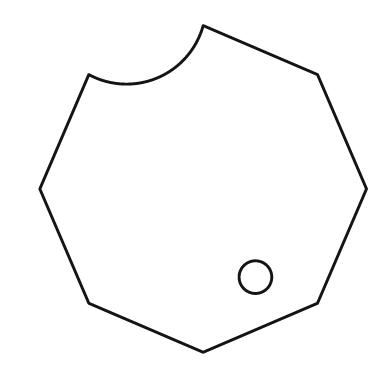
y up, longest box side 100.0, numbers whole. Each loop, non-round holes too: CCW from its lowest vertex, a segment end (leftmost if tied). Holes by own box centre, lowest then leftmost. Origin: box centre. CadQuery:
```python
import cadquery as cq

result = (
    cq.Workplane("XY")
    .moveTo(0.0, -50.0)
    .lineTo(35.0, -35.0)
    .lineTo(50.0, 0.0)
    .lineTo(35.0, 35.0)
    .lineTo(0.0, 50.0)
    .threePointArc((-14.0, 34.0), (-35.0, 35.0))
    .lineTo(-50.0, 0.0)
    .lineTo(-35.0, -35.0)
    .close()
    .moveTo(16.0, -27.0)
    .circle(5.0)
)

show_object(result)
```